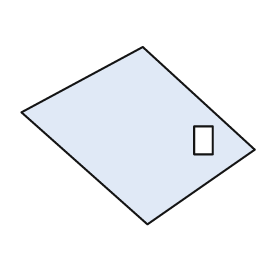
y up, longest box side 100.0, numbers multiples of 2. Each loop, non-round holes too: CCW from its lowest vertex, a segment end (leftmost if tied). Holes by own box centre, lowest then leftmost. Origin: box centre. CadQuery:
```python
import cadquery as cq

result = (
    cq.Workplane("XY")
    .moveTo(4.0, -38.0)
    .lineTo(50.0, -6.0)
    .lineTo(2.0, 38.0)
    .lineTo(-50.0, 10.0)
    .close()
    .moveTo(24.0, -8.0)
    .lineTo(32.0, -8.0)
    .lineTo(32.0, 4.0)
    .lineTo(24.0, 4.0)
    .close()
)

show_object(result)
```